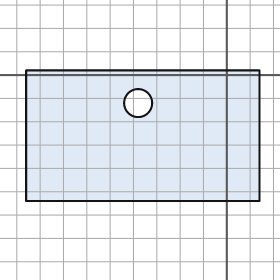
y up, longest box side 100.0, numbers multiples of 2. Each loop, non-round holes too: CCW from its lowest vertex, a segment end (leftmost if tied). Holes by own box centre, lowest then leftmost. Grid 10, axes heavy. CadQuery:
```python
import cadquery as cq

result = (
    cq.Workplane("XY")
    .moveTo(-86.0, -54.0)
    .lineTo(14.0, -54.0)
    .lineTo(14.0, 2.0)
    .lineTo(-86.0, 2.0)
    .close()
    .moveTo(-38.0, -12.0)
    .circle(6.0)
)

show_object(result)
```